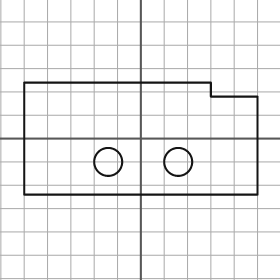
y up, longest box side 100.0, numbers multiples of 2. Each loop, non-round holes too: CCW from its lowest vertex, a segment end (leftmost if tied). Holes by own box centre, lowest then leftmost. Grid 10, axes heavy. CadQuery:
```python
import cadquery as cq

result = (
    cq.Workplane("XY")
    .moveTo(-50.0, -24.0)
    .lineTo(50.0, -24.0)
    .lineTo(50.0, 18.0)
    .lineTo(30.0, 18.0)
    .lineTo(30.0, 24.0)
    .lineTo(-50.0, 24.0)
    .close()
    .moveTo(-14.0, -10.0)
    .circle(6.0)
    .moveTo(16.0, -10.0)
    .circle(6.0)
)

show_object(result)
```